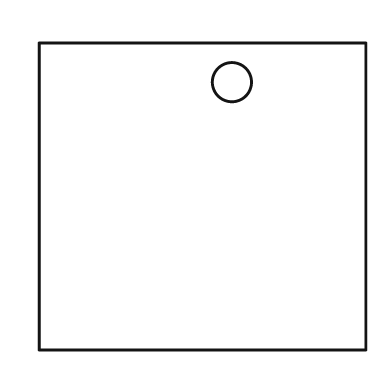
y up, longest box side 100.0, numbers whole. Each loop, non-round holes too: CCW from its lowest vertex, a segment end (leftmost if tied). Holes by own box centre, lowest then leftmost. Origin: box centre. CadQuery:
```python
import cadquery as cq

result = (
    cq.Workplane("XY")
    .moveTo(-50.0, -47.0)
    .lineTo(50.0, -47.0)
    .lineTo(50.0, 47.0)
    .lineTo(-50.0, 47.0)
    .close()
    .moveTo(9.0, 35.0)
    .circle(6.0)
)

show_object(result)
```